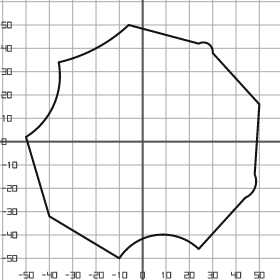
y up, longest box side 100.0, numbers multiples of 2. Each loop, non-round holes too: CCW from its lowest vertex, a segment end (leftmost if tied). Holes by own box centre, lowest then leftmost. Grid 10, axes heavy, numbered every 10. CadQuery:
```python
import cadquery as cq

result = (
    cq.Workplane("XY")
    .moveTo(-10.0, -50.0)
    .threePointArc((6.0, -40.0), (24.0, -46.0))
    .lineTo(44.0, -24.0)
    .threePointArc((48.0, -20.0), (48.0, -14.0))
    .lineTo(50.0, 16.0)
    .lineTo(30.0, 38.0)
    .threePointArc((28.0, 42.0), (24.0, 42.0))
    .lineTo(-6.0, 50.0)
    .threePointArc((-20.0, 40.0), (-36.0, 34.0))
    .threePointArc((-38.0, 16.0), (-50.0, 2.0))
    .lineTo(-40.0, -32.0)
    .close()
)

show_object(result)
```